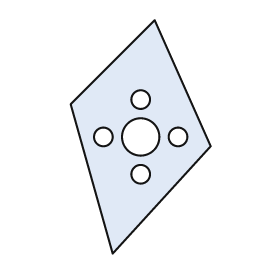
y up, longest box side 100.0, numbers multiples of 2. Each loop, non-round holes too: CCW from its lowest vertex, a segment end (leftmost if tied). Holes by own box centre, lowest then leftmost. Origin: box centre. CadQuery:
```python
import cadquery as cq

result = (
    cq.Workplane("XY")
    .moveTo(-12.0, -50.0)
    .lineTo(30.0, -4.0)
    .lineTo(6.0, 50.0)
    .lineTo(-30.0, 14.0)
    .close()
    .moveTo(0.0, -16.0)
    .circle(4.0)
    .moveTo(-16.0, 0.0)
    .circle(4.0)
    .moveTo(0.0, 0.0)
    .circle(8.0)
    .moveTo(16.0, 0.0)
    .circle(4.0)
    .moveTo(0.0, 16.0)
    .circle(4.0)
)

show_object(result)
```